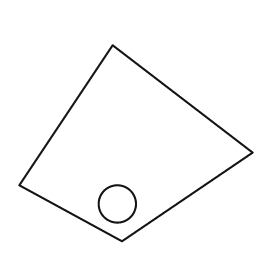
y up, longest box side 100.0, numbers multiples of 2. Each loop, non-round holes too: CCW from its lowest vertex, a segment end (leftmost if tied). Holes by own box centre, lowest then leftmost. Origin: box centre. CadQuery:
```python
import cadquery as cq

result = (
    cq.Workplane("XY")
    .moveTo(-6.0, -42.0)
    .lineTo(50.0, -4.0)
    .lineTo(-10.0, 42.0)
    .lineTo(-50.0, -18.0)
    .close()
    .moveTo(-8.0, -26.0)
    .circle(8.0)
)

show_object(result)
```